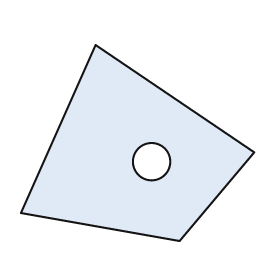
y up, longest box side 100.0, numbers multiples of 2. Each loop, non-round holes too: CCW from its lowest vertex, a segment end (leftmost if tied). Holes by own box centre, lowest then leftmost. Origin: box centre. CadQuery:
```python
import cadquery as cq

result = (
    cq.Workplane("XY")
    .moveTo(18.0, -42.0)
    .lineTo(50.0, -4.0)
    .lineTo(-18.0, 42.0)
    .lineTo(-50.0, -30.0)
    .close()
    .moveTo(6.0, -8.0)
    .circle(8.0)
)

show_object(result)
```